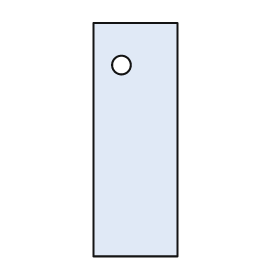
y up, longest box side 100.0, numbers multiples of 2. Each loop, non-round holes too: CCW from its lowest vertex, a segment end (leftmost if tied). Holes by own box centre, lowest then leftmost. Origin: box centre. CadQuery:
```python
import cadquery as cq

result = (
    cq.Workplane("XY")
    .moveTo(-18.0, -50.0)
    .lineTo(18.0, -50.0)
    .lineTo(18.0, 50.0)
    .lineTo(-18.0, 50.0)
    .close()
    .moveTo(-6.0, 32.0)
    .circle(4.0)
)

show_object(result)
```